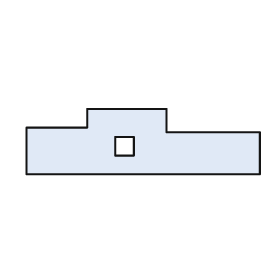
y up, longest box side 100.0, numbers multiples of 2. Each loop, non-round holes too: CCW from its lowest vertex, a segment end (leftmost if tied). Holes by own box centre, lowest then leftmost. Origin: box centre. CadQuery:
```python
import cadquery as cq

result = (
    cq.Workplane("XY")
    .moveTo(-50.0, -14.0)
    .lineTo(50.0, -14.0)
    .lineTo(50.0, 4.0)
    .lineTo(10.0, 4.0)
    .lineTo(10.0, 14.0)
    .lineTo(-24.0, 14.0)
    .lineTo(-24.0, 6.0)
    .lineTo(-50.0, 6.0)
    .close()
    .moveTo(-12.0, -6.0)
    .lineTo(-4.0, -6.0)
    .lineTo(-4.0, 2.0)
    .lineTo(-12.0, 2.0)
    .close()
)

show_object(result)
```